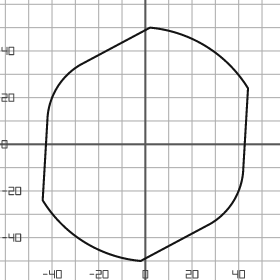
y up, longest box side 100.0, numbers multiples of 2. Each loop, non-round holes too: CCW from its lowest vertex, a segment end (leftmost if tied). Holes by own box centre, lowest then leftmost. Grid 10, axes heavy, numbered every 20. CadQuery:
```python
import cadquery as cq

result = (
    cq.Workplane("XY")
    .moveTo(-2.0, -50.0)
    .lineTo(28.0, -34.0)
    .threePointArc((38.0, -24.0), (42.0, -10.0))
    .lineTo(44.0, 24.0)
    .threePointArc((26.0, 42.0), (2.0, 50.0))
    .lineTo(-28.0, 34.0)
    .threePointArc((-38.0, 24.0), (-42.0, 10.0))
    .lineTo(-44.0, -24.0)
    .threePointArc((-26.0, -42.0), (-2.0, -50.0))
    .close()
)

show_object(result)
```